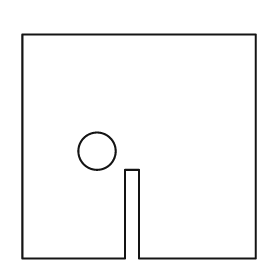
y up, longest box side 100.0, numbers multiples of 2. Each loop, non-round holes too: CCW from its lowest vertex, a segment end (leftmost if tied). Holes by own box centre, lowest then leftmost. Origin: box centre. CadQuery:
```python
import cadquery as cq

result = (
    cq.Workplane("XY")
    .moveTo(-50.0, -48.0)
    .lineTo(-6.0, -48.0)
    .lineTo(-6.0, -10.0)
    .lineTo(0.0, -10.0)
    .lineTo(0.0, -48.0)
    .lineTo(50.0, -48.0)
    .lineTo(50.0, 48.0)
    .lineTo(-50.0, 48.0)
    .close()
    .moveTo(-18.0, -2.0)
    .circle(8.0)
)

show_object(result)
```